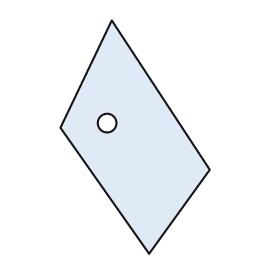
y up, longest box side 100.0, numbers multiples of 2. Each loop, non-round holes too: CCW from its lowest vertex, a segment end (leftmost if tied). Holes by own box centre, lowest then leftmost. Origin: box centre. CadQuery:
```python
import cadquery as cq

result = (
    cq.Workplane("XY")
    .moveTo(6.0, -50.0)
    .lineTo(32.0, -14.0)
    .lineTo(-10.0, 50.0)
    .lineTo(-32.0, 4.0)
    .close()
    .moveTo(-12.0, 6.0)
    .circle(4.0)
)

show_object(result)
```